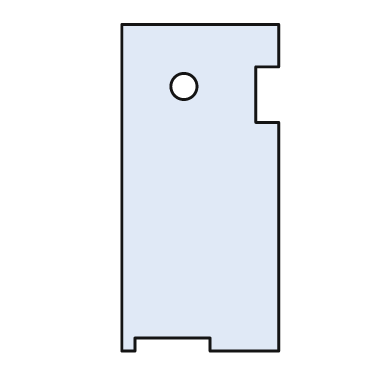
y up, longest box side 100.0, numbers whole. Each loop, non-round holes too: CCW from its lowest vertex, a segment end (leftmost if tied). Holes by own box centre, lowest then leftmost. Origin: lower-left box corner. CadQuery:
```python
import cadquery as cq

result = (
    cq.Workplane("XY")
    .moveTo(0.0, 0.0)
    .lineTo(4.0, 0.0)
    .lineTo(4.0, 4.0)
    .lineTo(27.0, 4.0)
    .lineTo(27.0, 0.0)
    .lineTo(48.0, 0.0)
    .lineTo(48.0, 70.0)
    .lineTo(41.0, 70.0)
    .lineTo(41.0, 87.0)
    .lineTo(48.0, 87.0)
    .lineTo(48.0, 100.0)
    .lineTo(0.0, 100.0)
    .close()
    .moveTo(19.0, 81.0)
    .circle(4.0)
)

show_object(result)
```